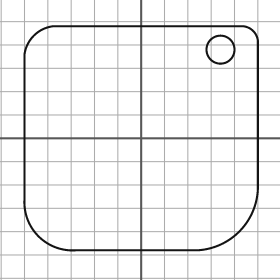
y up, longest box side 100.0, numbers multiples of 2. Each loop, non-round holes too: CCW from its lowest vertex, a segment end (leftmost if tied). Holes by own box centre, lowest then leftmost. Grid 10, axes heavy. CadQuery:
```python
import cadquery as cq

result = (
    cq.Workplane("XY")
    .moveTo(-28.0, -48.0)
    .lineTo(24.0, -48.0)
    .threePointArc((42.0, -40.0), (50.0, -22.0))
    .lineTo(50.0, 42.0)
    .threePointArc((48.0, 46.0), (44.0, 48.0))
    .lineTo(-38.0, 48.0)
    .threePointArc((-46.0, 44.0), (-50.0, 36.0))
    .lineTo(-50.0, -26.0)
    .threePointArc((-44.0, -42.0), (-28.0, -48.0))
    .close()
    .moveTo(34.0, 38.0)
    .circle(6.0)
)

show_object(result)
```